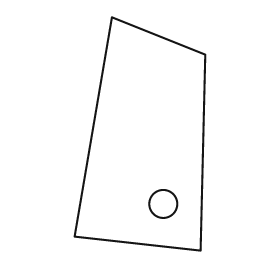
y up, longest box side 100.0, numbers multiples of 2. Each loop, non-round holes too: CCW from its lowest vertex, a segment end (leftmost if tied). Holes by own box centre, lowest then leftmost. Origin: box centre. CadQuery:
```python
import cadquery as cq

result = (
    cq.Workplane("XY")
    .moveTo(26.0, -50.0)
    .lineTo(28.0, 34.0)
    .lineTo(-12.0, 50.0)
    .lineTo(-28.0, -44.0)
    .close()
    .moveTo(10.0, -30.0)
    .circle(6.0)
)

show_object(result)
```